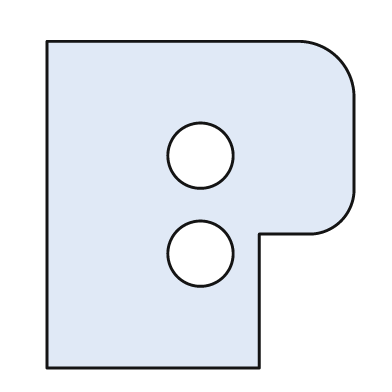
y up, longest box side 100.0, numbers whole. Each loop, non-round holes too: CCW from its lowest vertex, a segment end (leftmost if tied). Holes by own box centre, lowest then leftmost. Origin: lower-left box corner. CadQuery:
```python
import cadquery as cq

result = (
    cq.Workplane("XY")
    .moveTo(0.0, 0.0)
    .lineTo(65.0, 0.0)
    .lineTo(65.0, 41.0)
    .lineTo(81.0, 41.0)
    .threePointArc((90.0, 45.0), (94.0, 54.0))
    .lineTo(94.0, 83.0)
    .threePointArc((89.0, 95.0), (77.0, 100.0))
    .lineTo(0.0, 100.0)
    .close()
    .moveTo(47.0, 35.0)
    .circle(10.0)
    .moveTo(47.0, 65.0)
    .circle(10.0)
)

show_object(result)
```